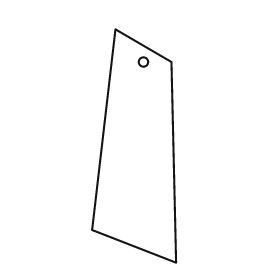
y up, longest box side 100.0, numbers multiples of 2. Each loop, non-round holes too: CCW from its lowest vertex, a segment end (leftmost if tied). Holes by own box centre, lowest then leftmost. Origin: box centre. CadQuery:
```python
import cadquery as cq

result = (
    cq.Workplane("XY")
    .moveTo(18.0, -50.0)
    .lineTo(16.0, 36.0)
    .lineTo(-8.0, 50.0)
    .lineTo(-18.0, -36.0)
    .close()
    .moveTo(4.0, 36.0)
    .circle(2.0)
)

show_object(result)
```